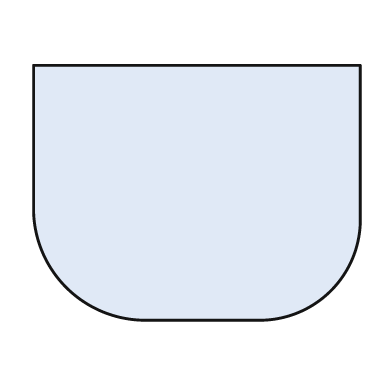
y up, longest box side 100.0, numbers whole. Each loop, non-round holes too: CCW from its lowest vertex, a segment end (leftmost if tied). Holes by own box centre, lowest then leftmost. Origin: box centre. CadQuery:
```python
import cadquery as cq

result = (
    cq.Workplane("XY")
    .moveTo(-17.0, -39.0)
    .lineTo(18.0, -39.0)
    .threePointArc((41.0, -30.0), (50.0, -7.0))
    .lineTo(50.0, 39.0)
    .lineTo(-50.0, 39.0)
    .lineTo(-50.0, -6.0)
    .threePointArc((-40.0, -29.0), (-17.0, -39.0))
    .close()
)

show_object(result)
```